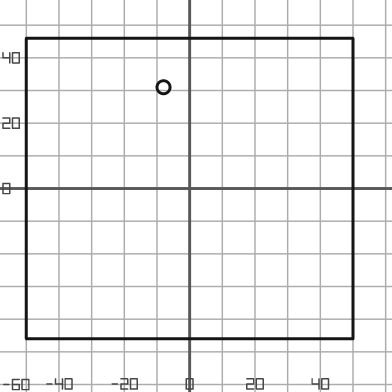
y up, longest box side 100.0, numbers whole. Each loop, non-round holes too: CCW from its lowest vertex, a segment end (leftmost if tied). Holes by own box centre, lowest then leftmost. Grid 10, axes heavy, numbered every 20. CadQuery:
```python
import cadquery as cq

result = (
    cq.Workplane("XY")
    .moveTo(-50.0, -46.0)
    .lineTo(50.0, -46.0)
    .lineTo(50.0, 46.0)
    .lineTo(-50.0, 46.0)
    .close()
    .moveTo(-8.0, 31.0)
    .circle(2.0)
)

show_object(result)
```